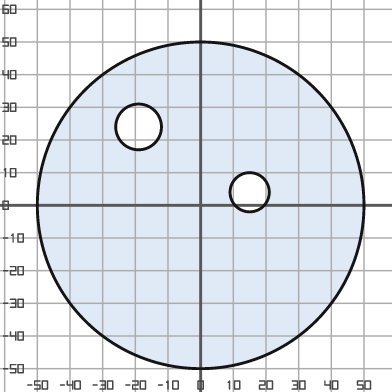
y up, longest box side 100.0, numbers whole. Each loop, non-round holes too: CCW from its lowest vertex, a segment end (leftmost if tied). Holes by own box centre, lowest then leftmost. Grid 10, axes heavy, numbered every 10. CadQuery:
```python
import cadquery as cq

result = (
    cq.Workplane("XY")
    .moveTo(0.0, 0.0)
    .circle(50.0)
    .moveTo(15.0, 4.0)
    .circle(6.0)
    .moveTo(-19.0, 24.0)
    .circle(7.0)
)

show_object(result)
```